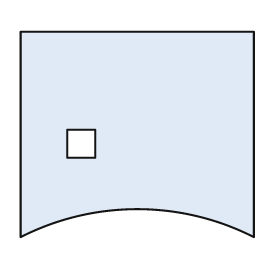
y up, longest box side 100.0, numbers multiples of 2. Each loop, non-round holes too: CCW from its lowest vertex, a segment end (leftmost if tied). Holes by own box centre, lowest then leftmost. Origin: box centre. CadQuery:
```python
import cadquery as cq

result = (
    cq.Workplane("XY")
    .moveTo(-50.0, -44.0)
    .threePointArc((0.0, -32.0), (50.0, -44.0))
    .lineTo(50.0, 44.0)
    .lineTo(-50.0, 44.0)
    .close()
    .moveTo(-30.0, -10.0)
    .lineTo(-18.0, -10.0)
    .lineTo(-18.0, 2.0)
    .lineTo(-30.0, 2.0)
    .close()
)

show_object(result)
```